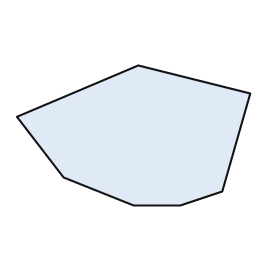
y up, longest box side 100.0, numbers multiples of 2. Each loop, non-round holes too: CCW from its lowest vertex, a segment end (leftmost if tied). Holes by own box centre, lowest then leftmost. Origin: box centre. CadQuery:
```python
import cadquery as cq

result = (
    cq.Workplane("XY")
    .moveTo(0.0, -30.0)
    .lineTo(20.0, -30.0)
    .lineTo(38.0, -24.0)
    .lineTo(50.0, 18.0)
    .lineTo(2.0, 30.0)
    .lineTo(-50.0, 8.0)
    .lineTo(-30.0, -18.0)
    .close()
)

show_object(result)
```